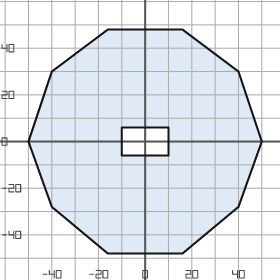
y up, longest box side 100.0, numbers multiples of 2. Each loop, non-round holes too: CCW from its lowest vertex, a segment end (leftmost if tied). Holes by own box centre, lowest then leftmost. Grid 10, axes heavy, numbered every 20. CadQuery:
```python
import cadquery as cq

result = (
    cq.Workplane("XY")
    .moveTo(-16.0, -48.0)
    .lineTo(16.0, -48.0)
    .lineTo(40.0, -28.0)
    .lineTo(50.0, 0.0)
    .lineTo(40.0, 30.0)
    .lineTo(16.0, 48.0)
    .lineTo(-16.0, 48.0)
    .lineTo(-40.0, 30.0)
    .lineTo(-50.0, 0.0)
    .lineTo(-40.0, -28.0)
    .close()
    .moveTo(-10.0, -6.0)
    .lineTo(10.0, -6.0)
    .lineTo(10.0, 6.0)
    .lineTo(-10.0, 6.0)
    .close()
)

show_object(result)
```